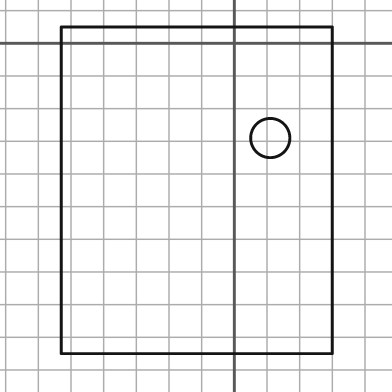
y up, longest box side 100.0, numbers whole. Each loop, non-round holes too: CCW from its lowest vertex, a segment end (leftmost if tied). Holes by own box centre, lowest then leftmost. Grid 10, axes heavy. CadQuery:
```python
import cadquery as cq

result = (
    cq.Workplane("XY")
    .moveTo(-53.0, -95.0)
    .lineTo(30.0, -95.0)
    .lineTo(30.0, 5.0)
    .lineTo(-53.0, 5.0)
    .close()
    .moveTo(11.0, -29.0)
    .circle(6.0)
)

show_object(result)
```